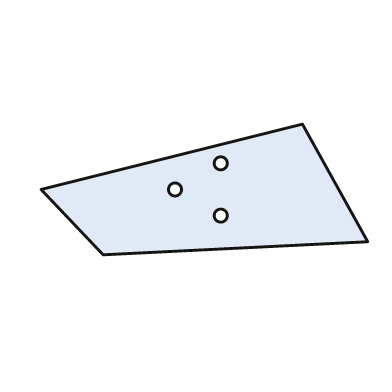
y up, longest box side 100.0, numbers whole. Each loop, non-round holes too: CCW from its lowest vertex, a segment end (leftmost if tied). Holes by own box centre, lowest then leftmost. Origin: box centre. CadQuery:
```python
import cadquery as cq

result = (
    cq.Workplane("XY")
    .moveTo(-31.0, -20.0)
    .lineTo(50.0, -16.0)
    .lineTo(30.0, 20.0)
    .lineTo(-50.0, 0.0)
    .close()
    .moveTo(5.0, -8.0)
    .circle(2.0)
    .moveTo(-9.0, 0.0)
    .circle(2.0)
    .moveTo(5.0, 8.0)
    .circle(2.0)
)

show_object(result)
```